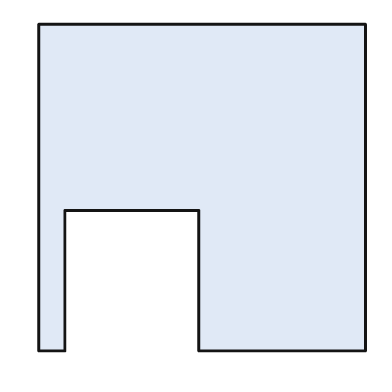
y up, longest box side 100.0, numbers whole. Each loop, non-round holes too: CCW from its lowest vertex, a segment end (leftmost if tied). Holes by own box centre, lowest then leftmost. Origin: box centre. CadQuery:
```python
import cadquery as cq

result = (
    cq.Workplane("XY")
    .moveTo(-50.0, -50.0)
    .lineTo(-42.0, -50.0)
    .lineTo(-42.0, -7.0)
    .lineTo(-1.0, -7.0)
    .lineTo(-1.0, -50.0)
    .lineTo(50.0, -50.0)
    .lineTo(50.0, 50.0)
    .lineTo(-50.0, 50.0)
    .close()
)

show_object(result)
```